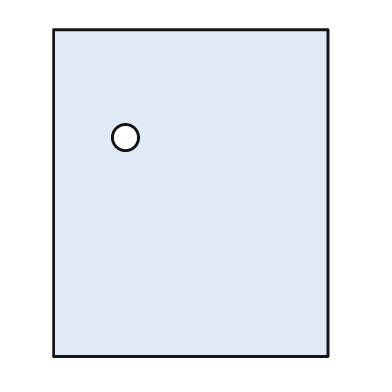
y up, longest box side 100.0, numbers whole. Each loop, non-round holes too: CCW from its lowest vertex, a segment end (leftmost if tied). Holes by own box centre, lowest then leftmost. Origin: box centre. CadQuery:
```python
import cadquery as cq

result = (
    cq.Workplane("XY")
    .moveTo(-42.0, -50.0)
    .lineTo(42.0, -50.0)
    .lineTo(42.0, 50.0)
    .lineTo(-42.0, 50.0)
    .close()
    .moveTo(-20.0, 17.0)
    .circle(4.0)
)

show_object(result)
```